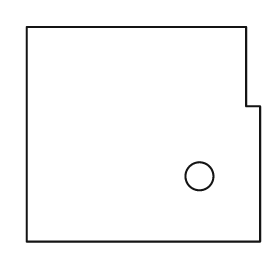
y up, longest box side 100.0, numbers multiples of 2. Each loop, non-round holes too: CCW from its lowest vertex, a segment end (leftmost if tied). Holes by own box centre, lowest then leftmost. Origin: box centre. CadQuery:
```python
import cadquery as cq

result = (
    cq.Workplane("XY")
    .moveTo(-50.0, -46.0)
    .lineTo(50.0, -46.0)
    .lineTo(50.0, 12.0)
    .lineTo(44.0, 12.0)
    .lineTo(44.0, 46.0)
    .lineTo(-50.0, 46.0)
    .close()
    .moveTo(24.0, -18.0)
    .circle(6.0)
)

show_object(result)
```